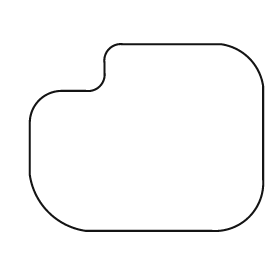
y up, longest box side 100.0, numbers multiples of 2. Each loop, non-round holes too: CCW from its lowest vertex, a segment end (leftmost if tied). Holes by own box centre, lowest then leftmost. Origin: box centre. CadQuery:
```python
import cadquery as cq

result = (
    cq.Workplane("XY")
    .moveTo(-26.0, -40.0)
    .lineTo(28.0, -40.0)
    .threePointArc((44.0, -34.0), (50.0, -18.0))
    .lineTo(50.0, 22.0)
    .threePointArc((44.0, 34.0), (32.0, 40.0))
    .lineTo(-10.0, 40.0)
    .threePointArc((-16.0, 38.0), (-18.0, 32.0))
    .lineTo(-18.0, 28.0)
    .threePointArc((-20.0, 22.0), (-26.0, 20.0))
    .lineTo(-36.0, 20.0)
    .threePointArc((-46.0, 16.0), (-50.0, 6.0))
    .lineTo(-50.0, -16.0)
    .threePointArc((-42.0, -32.0), (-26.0, -40.0))
    .close()
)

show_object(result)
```